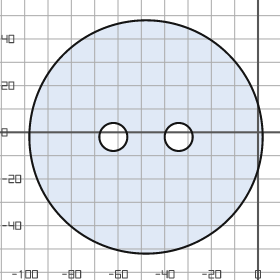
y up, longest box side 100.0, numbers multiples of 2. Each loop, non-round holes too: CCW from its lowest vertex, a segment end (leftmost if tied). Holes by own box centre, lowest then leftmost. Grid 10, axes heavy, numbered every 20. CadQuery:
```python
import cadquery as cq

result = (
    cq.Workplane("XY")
    .moveTo(-48.0, -2.0)
    .circle(50.0)
    .moveTo(-62.0, -2.0)
    .circle(6.0)
    .moveTo(-34.0, -2.0)
    .circle(6.0)
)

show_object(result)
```